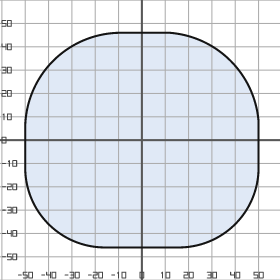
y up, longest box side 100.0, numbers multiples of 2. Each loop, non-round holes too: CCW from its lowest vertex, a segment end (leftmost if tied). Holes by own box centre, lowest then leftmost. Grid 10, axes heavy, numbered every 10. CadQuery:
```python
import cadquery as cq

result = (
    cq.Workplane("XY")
    .moveTo(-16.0, -46.0)
    .lineTo(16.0, -46.0)
    .threePointArc((40.0, -36.0), (50.0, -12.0))
    .lineTo(50.0, 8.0)
    .threePointArc((38.0, 34.0), (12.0, 46.0))
    .lineTo(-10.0, 46.0)
    .threePointArc((-38.0, 34.0), (-50.0, 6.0))
    .lineTo(-50.0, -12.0)
    .threePointArc((-40.0, -36.0), (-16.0, -46.0))
    .close()
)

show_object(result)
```